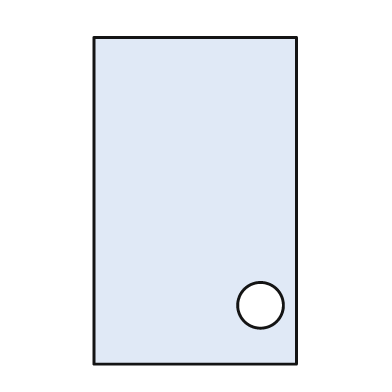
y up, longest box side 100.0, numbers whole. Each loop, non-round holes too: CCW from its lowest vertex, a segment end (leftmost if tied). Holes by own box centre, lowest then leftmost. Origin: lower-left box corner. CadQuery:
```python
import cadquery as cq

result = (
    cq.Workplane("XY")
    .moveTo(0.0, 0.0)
    .lineTo(62.0, 0.0)
    .lineTo(62.0, 100.0)
    .lineTo(0.0, 100.0)
    .close()
    .moveTo(51.0, 18.0)
    .circle(7.0)
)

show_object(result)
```